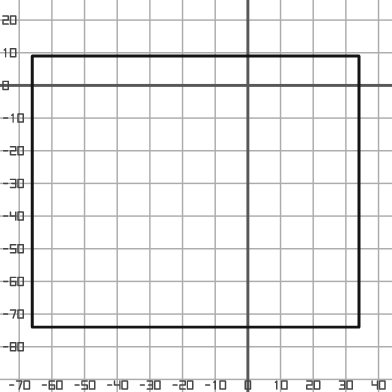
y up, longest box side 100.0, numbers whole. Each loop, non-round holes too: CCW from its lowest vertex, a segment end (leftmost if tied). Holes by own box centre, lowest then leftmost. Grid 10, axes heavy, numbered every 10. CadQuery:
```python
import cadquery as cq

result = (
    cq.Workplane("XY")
    .moveTo(-66.0, -74.0)
    .lineTo(34.0, -74.0)
    .lineTo(34.0, 9.0)
    .lineTo(-66.0, 9.0)
    .close()
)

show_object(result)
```